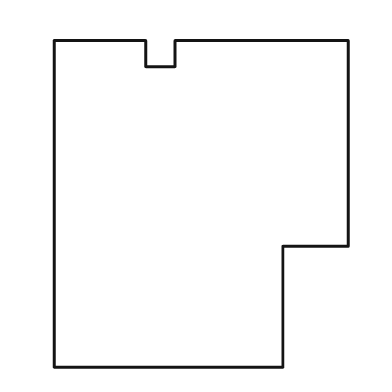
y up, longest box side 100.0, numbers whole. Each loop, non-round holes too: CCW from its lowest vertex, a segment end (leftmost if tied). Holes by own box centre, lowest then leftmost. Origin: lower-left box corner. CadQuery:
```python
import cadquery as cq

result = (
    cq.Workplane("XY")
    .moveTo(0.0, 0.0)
    .lineTo(70.0, 0.0)
    .lineTo(70.0, 37.0)
    .lineTo(90.0, 37.0)
    .lineTo(90.0, 100.0)
    .lineTo(37.0, 100.0)
    .lineTo(37.0, 92.0)
    .lineTo(28.0, 92.0)
    .lineTo(28.0, 100.0)
    .lineTo(0.0, 100.0)
    .close()
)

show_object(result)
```